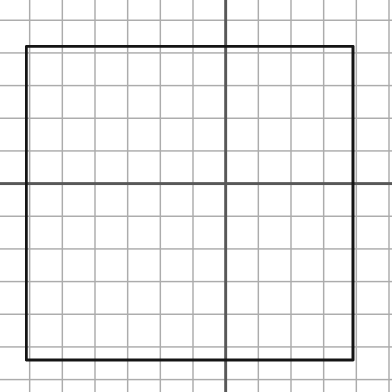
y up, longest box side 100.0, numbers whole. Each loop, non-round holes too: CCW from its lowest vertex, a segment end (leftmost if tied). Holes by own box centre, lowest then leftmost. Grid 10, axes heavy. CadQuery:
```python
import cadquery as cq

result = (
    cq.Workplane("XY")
    .moveTo(-61.0, -54.0)
    .lineTo(39.0, -54.0)
    .lineTo(39.0, 42.0)
    .lineTo(-61.0, 42.0)
    .close()
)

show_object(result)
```